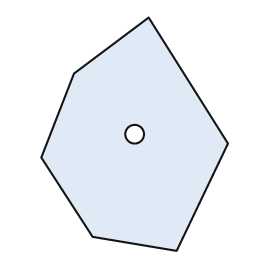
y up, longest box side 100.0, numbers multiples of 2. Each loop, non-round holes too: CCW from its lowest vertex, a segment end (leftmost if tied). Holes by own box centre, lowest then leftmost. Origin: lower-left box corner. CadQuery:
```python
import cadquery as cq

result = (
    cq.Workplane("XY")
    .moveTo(58.0, 0.0)
    .lineTo(80.0, 46.0)
    .lineTo(46.0, 100.0)
    .lineTo(14.0, 76.0)
    .lineTo(0.0, 40.0)
    .lineTo(22.0, 6.0)
    .close()
    .moveTo(40.0, 50.0)
    .circle(4.0)
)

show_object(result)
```